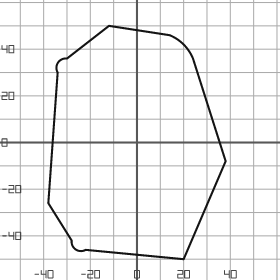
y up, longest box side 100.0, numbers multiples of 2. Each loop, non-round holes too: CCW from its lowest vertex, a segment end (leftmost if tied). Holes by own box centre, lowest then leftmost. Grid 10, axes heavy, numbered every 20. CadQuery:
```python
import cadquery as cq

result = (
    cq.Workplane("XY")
    .moveTo(20.0, -50.0)
    .lineTo(38.0, -8.0)
    .lineTo(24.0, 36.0)
    .threePointArc((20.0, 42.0), (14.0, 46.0))
    .lineTo(-12.0, 50.0)
    .lineTo(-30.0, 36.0)
    .threePointArc((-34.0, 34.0), (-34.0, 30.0))
    .lineTo(-38.0, -26.0)
    .lineTo(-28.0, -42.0)
    .threePointArc((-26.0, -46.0), (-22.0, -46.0))
    .close()
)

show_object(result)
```